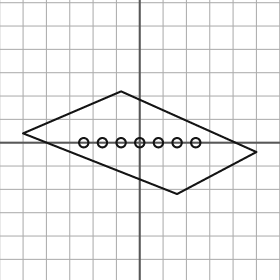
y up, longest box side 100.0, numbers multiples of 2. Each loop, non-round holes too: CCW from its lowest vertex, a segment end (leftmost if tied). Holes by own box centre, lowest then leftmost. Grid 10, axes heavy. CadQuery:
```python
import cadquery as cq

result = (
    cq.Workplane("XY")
    .moveTo(16.0, -22.0)
    .lineTo(50.0, -4.0)
    .lineTo(-8.0, 22.0)
    .lineTo(-50.0, 4.0)
    .close()
    .moveTo(-24.0, 0.0)
    .circle(2.0)
    .moveTo(-16.0, 0.0)
    .circle(2.0)
    .moveTo(-8.0, 0.0)
    .circle(2.0)
    .moveTo(0.0, 0.0)
    .circle(2.0)
    .moveTo(8.0, 0.0)
    .circle(2.0)
    .moveTo(16.0, 0.0)
    .circle(2.0)
    .moveTo(24.0, 0.0)
    .circle(2.0)
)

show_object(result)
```